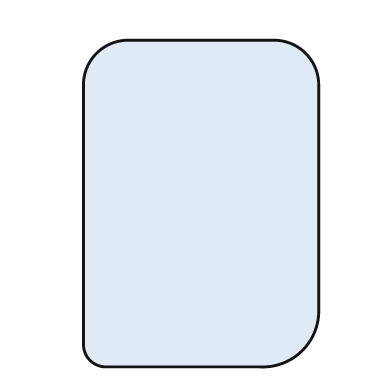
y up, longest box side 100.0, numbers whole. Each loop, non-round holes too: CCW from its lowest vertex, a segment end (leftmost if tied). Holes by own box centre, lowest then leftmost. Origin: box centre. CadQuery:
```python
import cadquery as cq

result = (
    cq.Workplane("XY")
    .moveTo(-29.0, -50.0)
    .lineTo(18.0, -50.0)
    .threePointArc((31.0, -45.0), (36.0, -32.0))
    .lineTo(36.0, 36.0)
    .threePointArc((32.0, 46.0), (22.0, 50.0))
    .lineTo(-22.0, 50.0)
    .threePointArc((-32.0, 46.0), (-36.0, 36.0))
    .lineTo(-36.0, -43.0)
    .threePointArc((-34.0, -48.0), (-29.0, -50.0))
    .close()
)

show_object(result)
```